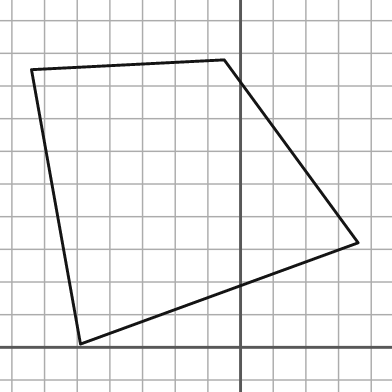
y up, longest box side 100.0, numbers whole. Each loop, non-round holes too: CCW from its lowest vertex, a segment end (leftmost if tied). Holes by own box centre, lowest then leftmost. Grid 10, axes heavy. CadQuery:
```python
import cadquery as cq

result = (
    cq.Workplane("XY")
    .moveTo(-49.0, 1.0)
    .lineTo(36.0, 32.0)
    .lineTo(-5.0, 88.0)
    .lineTo(-64.0, 85.0)
    .close()
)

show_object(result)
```